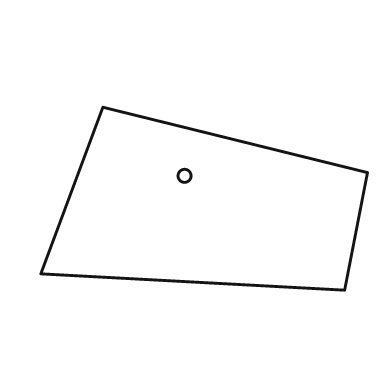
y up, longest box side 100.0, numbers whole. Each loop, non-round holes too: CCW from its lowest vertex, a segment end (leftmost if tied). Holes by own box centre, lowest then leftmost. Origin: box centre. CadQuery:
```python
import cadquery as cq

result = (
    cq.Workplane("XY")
    .moveTo(43.0, -28.0)
    .lineTo(50.0, 8.0)
    .lineTo(-31.0, 28.0)
    .lineTo(-50.0, -23.0)
    .close()
    .moveTo(-6.0, 7.0)
    .circle(2.0)
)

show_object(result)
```